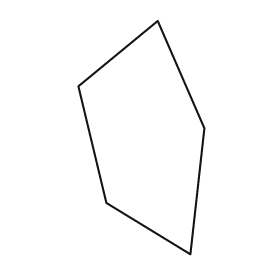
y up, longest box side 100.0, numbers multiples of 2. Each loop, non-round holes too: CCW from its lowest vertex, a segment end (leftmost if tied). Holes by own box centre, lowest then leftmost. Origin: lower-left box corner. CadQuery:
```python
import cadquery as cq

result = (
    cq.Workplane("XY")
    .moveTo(48.0, 0.0)
    .lineTo(54.0, 54.0)
    .lineTo(34.0, 100.0)
    .lineTo(0.0, 72.0)
    .lineTo(12.0, 22.0)
    .close()
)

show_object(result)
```